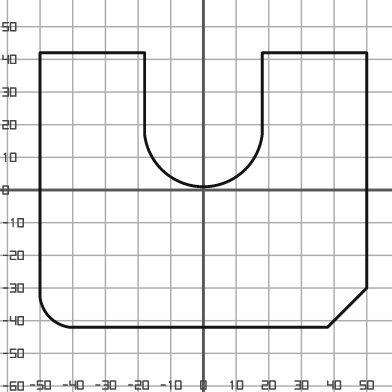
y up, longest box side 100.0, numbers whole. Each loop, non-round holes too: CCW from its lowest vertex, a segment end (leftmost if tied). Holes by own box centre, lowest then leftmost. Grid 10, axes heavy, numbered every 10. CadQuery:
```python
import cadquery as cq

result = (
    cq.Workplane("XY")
    .moveTo(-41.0, -42.0)
    .lineTo(38.0, -42.0)
    .lineTo(50.0, -30.0)
    .lineTo(50.0, 42.0)
    .lineTo(18.0, 42.0)
    .lineTo(18.0, 17.0)
    .threePointArc((0.0, 1.0), (-18.0, 17.0))
    .lineTo(-18.0, 42.0)
    .lineTo(-50.0, 42.0)
    .lineTo(-50.0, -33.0)
    .threePointArc((-47.0, -39.0), (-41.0, -42.0))
    .close()
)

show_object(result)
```